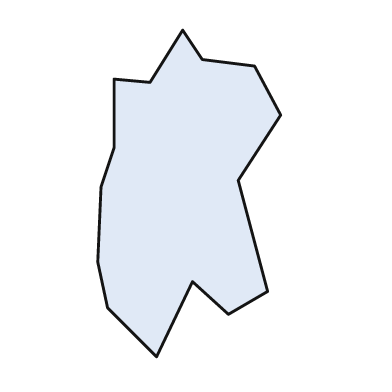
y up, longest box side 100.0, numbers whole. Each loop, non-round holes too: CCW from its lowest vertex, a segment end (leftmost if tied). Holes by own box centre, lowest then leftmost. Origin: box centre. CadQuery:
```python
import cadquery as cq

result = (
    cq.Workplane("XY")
    .moveTo(-10.0, -50.0)
    .lineTo(1.0, -27.0)
    .lineTo(12.0, -37.0)
    .lineTo(24.0, -30.0)
    .lineTo(15.0, 4.0)
    .lineTo(28.0, 24.0)
    .lineTo(20.0, 39.0)
    .lineTo(4.0, 41.0)
    .lineTo(-2.0, 50.0)
    .lineTo(-12.0, 34.0)
    .lineTo(-23.0, 35.0)
    .lineTo(-23.0, 14.0)
    .lineTo(-27.0, 2.0)
    .lineTo(-28.0, -21.0)
    .lineTo(-25.0, -35.0)
    .close()
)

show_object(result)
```